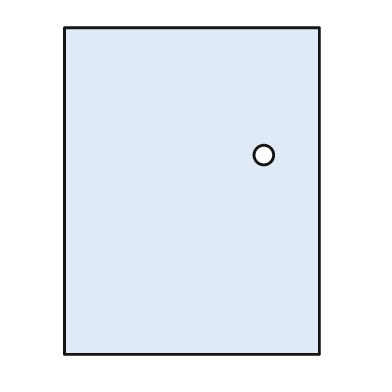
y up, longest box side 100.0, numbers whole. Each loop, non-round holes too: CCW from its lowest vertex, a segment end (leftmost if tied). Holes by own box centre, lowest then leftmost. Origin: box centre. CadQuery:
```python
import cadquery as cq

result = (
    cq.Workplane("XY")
    .moveTo(-39.0, -50.0)
    .lineTo(39.0, -50.0)
    .lineTo(39.0, 50.0)
    .lineTo(-39.0, 50.0)
    .close()
    .moveTo(22.0, 11.0)
    .circle(3.0)
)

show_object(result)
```